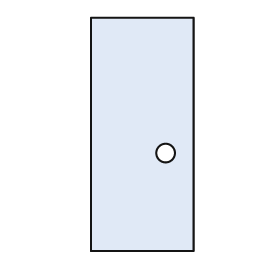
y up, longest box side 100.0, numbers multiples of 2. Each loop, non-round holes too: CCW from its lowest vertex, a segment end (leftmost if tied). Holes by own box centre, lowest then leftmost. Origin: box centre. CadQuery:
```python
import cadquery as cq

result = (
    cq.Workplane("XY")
    .moveTo(-22.0, -50.0)
    .lineTo(22.0, -50.0)
    .lineTo(22.0, 50.0)
    .lineTo(-22.0, 50.0)
    .close()
    .moveTo(10.0, -8.0)
    .circle(4.0)
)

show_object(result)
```